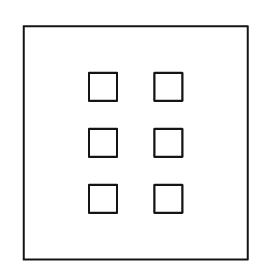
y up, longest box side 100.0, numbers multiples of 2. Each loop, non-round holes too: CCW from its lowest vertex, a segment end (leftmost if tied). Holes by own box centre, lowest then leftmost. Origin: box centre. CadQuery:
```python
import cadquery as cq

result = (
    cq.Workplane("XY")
    .moveTo(-48.0, -50.0)
    .lineTo(48.0, -50.0)
    .lineTo(48.0, 50.0)
    .lineTo(-48.0, 50.0)
    .close()
    .moveTo(-20.0, -30.0)
    .lineTo(-8.0, -30.0)
    .lineTo(-8.0, -18.0)
    .lineTo(-20.0, -18.0)
    .close()
    .moveTo(8.0, -30.0)
    .lineTo(20.0, -30.0)
    .lineTo(20.0, -18.0)
    .lineTo(8.0, -18.0)
    .close()
    .moveTo(-20.0, -6.0)
    .lineTo(-8.0, -6.0)
    .lineTo(-8.0, 6.0)
    .lineTo(-20.0, 6.0)
    .close()
    .moveTo(8.0, -6.0)
    .lineTo(20.0, -6.0)
    .lineTo(20.0, 6.0)
    .lineTo(8.0, 6.0)
    .close()
    .moveTo(-20.0, 18.0)
    .lineTo(-8.0, 18.0)
    .lineTo(-8.0, 30.0)
    .lineTo(-20.0, 30.0)
    .close()
    .moveTo(8.0, 18.0)
    .lineTo(20.0, 18.0)
    .lineTo(20.0, 30.0)
    .lineTo(8.0, 30.0)
    .close()
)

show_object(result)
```